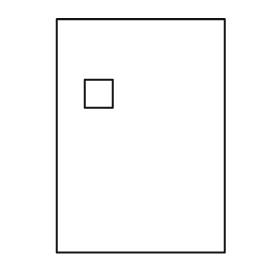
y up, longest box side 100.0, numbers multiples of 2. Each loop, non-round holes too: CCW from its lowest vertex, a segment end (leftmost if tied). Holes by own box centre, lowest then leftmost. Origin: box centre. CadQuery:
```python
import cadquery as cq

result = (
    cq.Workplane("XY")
    .moveTo(-36.0, -50.0)
    .lineTo(36.0, -50.0)
    .lineTo(36.0, 50.0)
    .lineTo(-36.0, 50.0)
    .close()
    .moveTo(-24.0, 12.0)
    .lineTo(-12.0, 12.0)
    .lineTo(-12.0, 24.0)
    .lineTo(-24.0, 24.0)
    .close()
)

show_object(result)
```